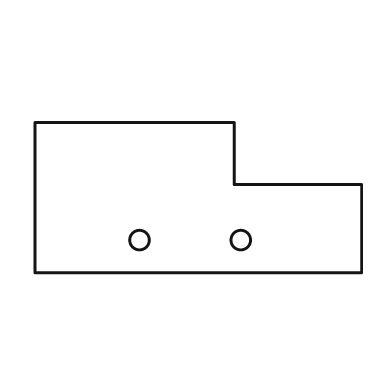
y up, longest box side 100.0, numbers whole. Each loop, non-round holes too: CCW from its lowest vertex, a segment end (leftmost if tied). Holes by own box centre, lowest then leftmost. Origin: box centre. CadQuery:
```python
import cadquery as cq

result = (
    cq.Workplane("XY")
    .moveTo(-50.0, -23.0)
    .lineTo(50.0, -23.0)
    .lineTo(50.0, 4.0)
    .lineTo(11.0, 4.0)
    .lineTo(11.0, 23.0)
    .lineTo(-50.0, 23.0)
    .close()
    .moveTo(-18.0, -13.0)
    .circle(3.0)
    .moveTo(13.0, -13.0)
    .circle(3.0)
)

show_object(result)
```